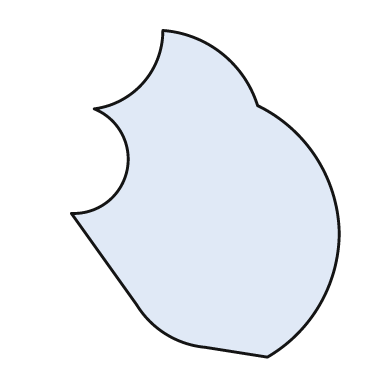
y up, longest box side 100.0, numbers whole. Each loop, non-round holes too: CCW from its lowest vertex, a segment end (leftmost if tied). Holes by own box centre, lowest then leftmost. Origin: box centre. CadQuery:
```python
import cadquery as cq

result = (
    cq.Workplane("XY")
    .moveTo(19.0, -50.0)
    .threePointArc((35.0, -34.0), (41.0, -12.0))
    .threePointArc((34.0, 11.0), (16.0, 27.0))
    .threePointArc((5.0, 43.0), (-13.0, 50.0))
    .threePointArc((-19.0, 34.0), (-34.0, 26.0))
    .threePointArc((-24.0, 7.0), (-41.0, -6.0))
    .lineTo(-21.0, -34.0)
    .threePointArc((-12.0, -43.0), (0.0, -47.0))
    .close()
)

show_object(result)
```